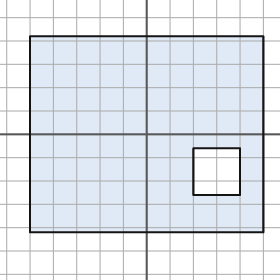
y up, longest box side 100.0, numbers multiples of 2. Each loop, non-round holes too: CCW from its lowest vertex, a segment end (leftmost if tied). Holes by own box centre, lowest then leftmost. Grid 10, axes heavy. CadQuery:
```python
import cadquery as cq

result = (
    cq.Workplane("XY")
    .moveTo(-50.0, -42.0)
    .lineTo(50.0, -42.0)
    .lineTo(50.0, 42.0)
    .lineTo(-50.0, 42.0)
    .close()
    .moveTo(20.0, -26.0)
    .lineTo(40.0, -26.0)
    .lineTo(40.0, -6.0)
    .lineTo(20.0, -6.0)
    .close()
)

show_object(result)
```